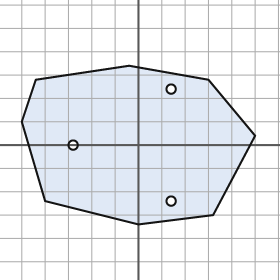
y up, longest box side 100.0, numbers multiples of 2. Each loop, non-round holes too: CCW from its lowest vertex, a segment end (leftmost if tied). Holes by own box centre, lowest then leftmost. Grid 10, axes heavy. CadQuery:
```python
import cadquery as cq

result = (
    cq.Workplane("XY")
    .moveTo(0.0, -34.0)
    .lineTo(32.0, -30.0)
    .lineTo(50.0, 4.0)
    .lineTo(30.0, 28.0)
    .lineTo(-4.0, 34.0)
    .lineTo(-44.0, 28.0)
    .lineTo(-50.0, 10.0)
    .lineTo(-40.0, -24.0)
    .close()
    .moveTo(14.0, -24.0)
    .circle(2.0)
    .moveTo(-28.0, 0.0)
    .circle(2.0)
    .moveTo(14.0, 24.0)
    .circle(2.0)
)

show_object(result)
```